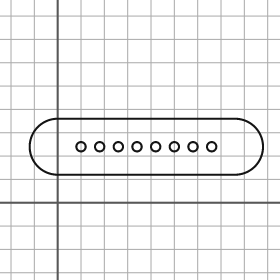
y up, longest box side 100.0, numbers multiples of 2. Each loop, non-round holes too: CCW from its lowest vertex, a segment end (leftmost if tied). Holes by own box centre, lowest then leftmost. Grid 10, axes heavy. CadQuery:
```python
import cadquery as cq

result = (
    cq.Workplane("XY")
    .moveTo(0.0, 12.0)
    .lineTo(76.0, 12.0)
    .threePointArc((88.0, 24.0), (76.0, 36.0))
    .lineTo(0.0, 36.0)
    .threePointArc((-12.0, 24.0), (0.0, 12.0))
    .close()
    .moveTo(10.0, 24.0)
    .circle(2.0)
    .moveTo(18.0, 24.0)
    .circle(2.0)
    .moveTo(26.0, 24.0)
    .circle(2.0)
    .moveTo(34.0, 24.0)
    .circle(2.0)
    .moveTo(42.0, 24.0)
    .circle(2.0)
    .moveTo(50.0, 24.0)
    .circle(2.0)
    .moveTo(58.0, 24.0)
    .circle(2.0)
    .moveTo(66.0, 24.0)
    .circle(2.0)
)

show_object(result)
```